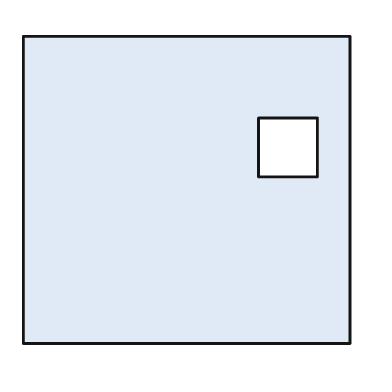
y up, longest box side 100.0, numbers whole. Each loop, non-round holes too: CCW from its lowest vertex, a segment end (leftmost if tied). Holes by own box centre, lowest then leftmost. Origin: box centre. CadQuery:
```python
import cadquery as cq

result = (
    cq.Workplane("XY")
    .moveTo(-50.0, -47.0)
    .lineTo(50.0, -47.0)
    .lineTo(50.0, 47.0)
    .lineTo(-50.0, 47.0)
    .close()
    .moveTo(22.0, 4.0)
    .lineTo(40.0, 4.0)
    .lineTo(40.0, 22.0)
    .lineTo(22.0, 22.0)
    .close()
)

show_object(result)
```